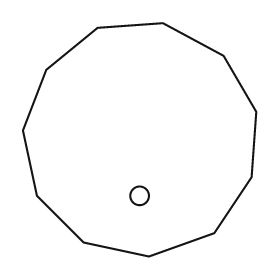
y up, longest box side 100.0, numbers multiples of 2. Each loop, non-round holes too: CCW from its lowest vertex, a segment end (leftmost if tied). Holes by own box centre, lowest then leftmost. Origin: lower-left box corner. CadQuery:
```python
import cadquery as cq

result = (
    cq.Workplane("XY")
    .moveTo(54.0, 0.0)
    .lineTo(82.0, 10.0)
    .lineTo(98.0, 34.0)
    .lineTo(100.0, 62.0)
    .lineTo(86.0, 86.0)
    .lineTo(60.0, 100.0)
    .lineTo(32.0, 98.0)
    .lineTo(10.0, 80.0)
    .lineTo(0.0, 54.0)
    .lineTo(6.0, 26.0)
    .lineTo(26.0, 6.0)
    .close()
    .moveTo(50.0, 26.0)
    .circle(4.0)
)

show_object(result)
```